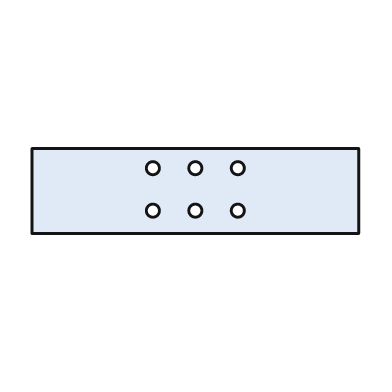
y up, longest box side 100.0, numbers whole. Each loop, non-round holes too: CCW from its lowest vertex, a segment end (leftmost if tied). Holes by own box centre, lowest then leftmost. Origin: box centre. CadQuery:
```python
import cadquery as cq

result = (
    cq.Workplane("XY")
    .moveTo(-50.0, -13.0)
    .lineTo(50.0, -13.0)
    .lineTo(50.0, 13.0)
    .lineTo(-50.0, 13.0)
    .close()
    .moveTo(-13.0, -6.0)
    .circle(2.0)
    .moveTo(0.0, -6.0)
    .circle(2.0)
    .moveTo(13.0, -6.0)
    .circle(2.0)
    .moveTo(-13.0, 7.0)
    .circle(2.0)
    .moveTo(0.0, 7.0)
    .circle(2.0)
    .moveTo(13.0, 7.0)
    .circle(2.0)
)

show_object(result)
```